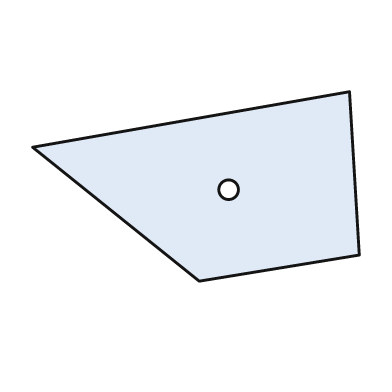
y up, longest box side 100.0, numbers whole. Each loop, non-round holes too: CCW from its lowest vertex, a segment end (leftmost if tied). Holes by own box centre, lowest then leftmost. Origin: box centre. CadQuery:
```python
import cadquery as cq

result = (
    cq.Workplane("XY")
    .moveTo(1.0, -29.0)
    .lineTo(50.0, -21.0)
    .lineTo(47.0, 29.0)
    .lineTo(-50.0, 12.0)
    .close()
    .moveTo(10.0, -1.0)
    .circle(3.0)
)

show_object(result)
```